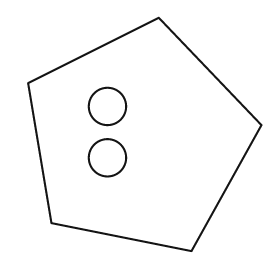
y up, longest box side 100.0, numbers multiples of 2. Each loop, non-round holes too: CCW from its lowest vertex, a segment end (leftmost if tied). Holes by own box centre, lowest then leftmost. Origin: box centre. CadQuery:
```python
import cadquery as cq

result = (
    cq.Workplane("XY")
    .moveTo(20.0, -50.0)
    .lineTo(50.0, 4.0)
    .lineTo(6.0, 50.0)
    .lineTo(-50.0, 22.0)
    .lineTo(-40.0, -38.0)
    .close()
    .moveTo(-16.0, -10.0)
    .circle(8.0)
    .moveTo(-16.0, 12.0)
    .circle(8.0)
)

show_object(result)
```